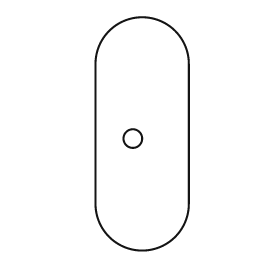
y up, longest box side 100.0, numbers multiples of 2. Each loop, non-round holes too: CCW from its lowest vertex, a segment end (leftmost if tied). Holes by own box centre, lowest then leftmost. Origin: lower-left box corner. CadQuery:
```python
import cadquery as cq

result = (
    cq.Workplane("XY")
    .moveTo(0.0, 20.0)
    .threePointArc((20.0, 0.0), (40.0, 20.0))
    .lineTo(40.0, 80.0)
    .threePointArc((20.0, 100.0), (0.0, 80.0))
    .close()
    .moveTo(16.0, 48.0)
    .circle(4.0)
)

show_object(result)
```